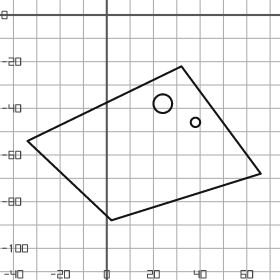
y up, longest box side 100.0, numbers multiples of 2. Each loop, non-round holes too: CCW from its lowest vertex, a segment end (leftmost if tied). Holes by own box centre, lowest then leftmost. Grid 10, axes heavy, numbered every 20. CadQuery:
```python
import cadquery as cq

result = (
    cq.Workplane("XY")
    .moveTo(2.0, -88.0)
    .lineTo(66.0, -68.0)
    .lineTo(32.0, -22.0)
    .lineTo(-34.0, -54.0)
    .close()
    .moveTo(38.0, -46.0)
    .circle(2.0)
    .moveTo(24.0, -38.0)
    .circle(4.0)
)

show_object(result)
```